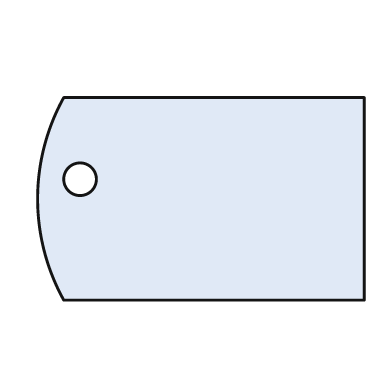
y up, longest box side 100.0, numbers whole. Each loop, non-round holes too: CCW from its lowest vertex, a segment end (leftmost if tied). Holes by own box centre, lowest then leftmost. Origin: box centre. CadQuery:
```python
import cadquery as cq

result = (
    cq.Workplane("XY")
    .moveTo(-42.0, -31.0)
    .lineTo(50.0, -31.0)
    .lineTo(50.0, 31.0)
    .lineTo(-42.0, 31.0)
    .threePointArc((-50.0, 0.0), (-42.0, -31.0))
    .close()
    .moveTo(-37.0, 6.0)
    .circle(5.0)
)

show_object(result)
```